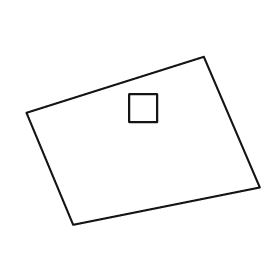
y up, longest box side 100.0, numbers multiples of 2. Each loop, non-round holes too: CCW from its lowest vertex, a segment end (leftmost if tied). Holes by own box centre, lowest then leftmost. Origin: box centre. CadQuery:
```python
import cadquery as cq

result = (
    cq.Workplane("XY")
    .moveTo(-30.0, -36.0)
    .lineTo(50.0, -20.0)
    .lineTo(26.0, 36.0)
    .lineTo(-50.0, 12.0)
    .close()
    .moveTo(-6.0, 8.0)
    .lineTo(6.0, 8.0)
    .lineTo(6.0, 20.0)
    .lineTo(-6.0, 20.0)
    .close()
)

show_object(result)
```